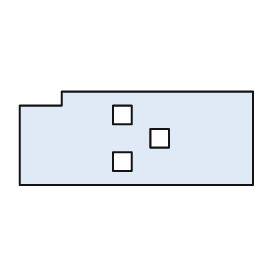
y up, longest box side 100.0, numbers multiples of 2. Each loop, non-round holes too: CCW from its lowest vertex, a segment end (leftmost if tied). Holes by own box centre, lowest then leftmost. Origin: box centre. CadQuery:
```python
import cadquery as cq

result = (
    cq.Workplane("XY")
    .moveTo(-50.0, -20.0)
    .lineTo(50.0, -20.0)
    .lineTo(50.0, 20.0)
    .lineTo(-32.0, 20.0)
    .lineTo(-32.0, 14.0)
    .lineTo(-50.0, 14.0)
    .close()
    .moveTo(-10.0, -14.0)
    .lineTo(-2.0, -14.0)
    .lineTo(-2.0, -6.0)
    .lineTo(-10.0, -6.0)
    .close()
    .moveTo(6.0, -4.0)
    .lineTo(14.0, -4.0)
    .lineTo(14.0, 4.0)
    .lineTo(6.0, 4.0)
    .close()
    .moveTo(-10.0, 6.0)
    .lineTo(-2.0, 6.0)
    .lineTo(-2.0, 14.0)
    .lineTo(-10.0, 14.0)
    .close()
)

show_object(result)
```